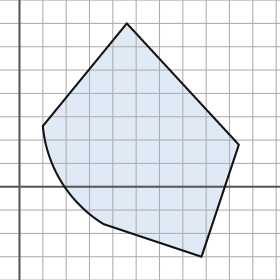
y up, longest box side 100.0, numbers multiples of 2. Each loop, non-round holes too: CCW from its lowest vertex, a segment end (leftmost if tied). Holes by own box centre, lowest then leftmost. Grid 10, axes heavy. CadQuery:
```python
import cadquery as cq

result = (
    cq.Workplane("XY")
    .moveTo(78.0, -30.0)
    .lineTo(94.0, 18.0)
    .lineTo(46.0, 70.0)
    .lineTo(10.0, 26.0)
    .threePointArc((18.0, 2.0), (36.0, -16.0))
    .close()
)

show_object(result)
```